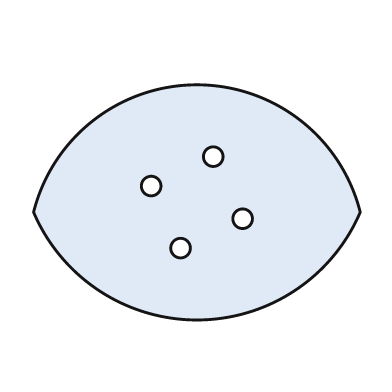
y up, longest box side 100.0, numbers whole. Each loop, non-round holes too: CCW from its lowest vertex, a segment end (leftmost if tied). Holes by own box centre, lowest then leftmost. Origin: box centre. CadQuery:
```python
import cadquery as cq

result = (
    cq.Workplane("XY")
    .moveTo(-50.0, -3.0)
    .threePointArc((0.0, -36.0), (50.0, -3.0))
    .threePointArc((0.0, 36.0), (-50.0, -3.0))
    .close()
    .moveTo(-5.0, -14.0)
    .circle(3.0)
    .moveTo(14.0, -5.0)
    .circle(3.0)
    .moveTo(-14.0, 5.0)
    .circle(3.0)
    .moveTo(5.0, 14.0)
    .circle(3.0)
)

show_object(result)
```